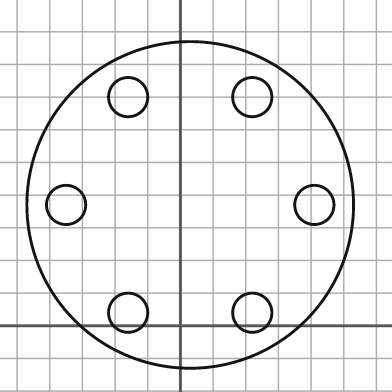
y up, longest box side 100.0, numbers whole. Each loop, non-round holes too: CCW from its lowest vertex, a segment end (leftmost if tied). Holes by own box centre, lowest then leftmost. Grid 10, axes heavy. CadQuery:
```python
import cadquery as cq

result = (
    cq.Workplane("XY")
    .moveTo(3.0, 37.0)
    .circle(50.0)
    .moveTo(-16.0, 4.0)
    .circle(6.0)
    .moveTo(22.0, 4.0)
    .circle(6.0)
    .moveTo(-35.0, 37.0)
    .circle(6.0)
    .moveTo(41.0, 37.0)
    .circle(6.0)
    .moveTo(-16.0, 70.0)
    .circle(6.0)
    .moveTo(22.0, 70.0)
    .circle(6.0)
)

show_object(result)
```